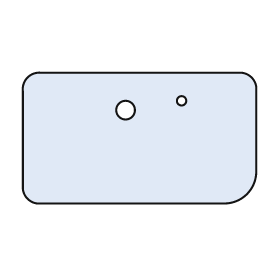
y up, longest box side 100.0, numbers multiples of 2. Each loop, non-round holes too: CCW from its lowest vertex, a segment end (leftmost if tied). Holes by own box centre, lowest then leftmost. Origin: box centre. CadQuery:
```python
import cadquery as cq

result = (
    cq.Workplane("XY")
    .moveTo(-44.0, -28.0)
    .lineTo(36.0, -28.0)
    .threePointArc((46.0, -24.0), (50.0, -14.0))
    .lineTo(50.0, 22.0)
    .threePointArc((48.0, 26.0), (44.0, 28.0))
    .lineTo(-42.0, 28.0)
    .threePointArc((-48.0, 26.0), (-50.0, 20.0))
    .lineTo(-50.0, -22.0)
    .threePointArc((-48.0, -26.0), (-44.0, -28.0))
    .close()
    .moveTo(-6.0, 12.0)
    .circle(4.0)
    .moveTo(18.0, 16.0)
    .circle(2.0)
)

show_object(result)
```